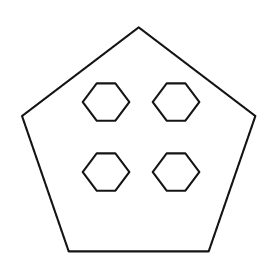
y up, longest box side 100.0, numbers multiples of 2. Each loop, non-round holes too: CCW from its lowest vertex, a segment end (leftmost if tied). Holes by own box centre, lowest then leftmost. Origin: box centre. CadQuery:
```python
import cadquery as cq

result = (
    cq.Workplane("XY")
    .moveTo(-30.0, -48.0)
    .lineTo(30.0, -48.0)
    .lineTo(50.0, 10.0)
    .lineTo(0.0, 48.0)
    .lineTo(-50.0, 10.0)
    .close()
    .moveTo(-18.0, -22.0)
    .lineTo(-10.0, -22.0)
    .lineTo(-4.0, -14.0)
    .lineTo(-10.0, -6.0)
    .lineTo(-18.0, -6.0)
    .lineTo(-24.0, -14.0)
    .close()
    .moveTo(12.0, -22.0)
    .lineTo(20.0, -22.0)
    .lineTo(26.0, -14.0)
    .lineTo(20.0, -6.0)
    .lineTo(12.0, -6.0)
    .lineTo(6.0, -14.0)
    .close()
    .moveTo(-18.0, 8.0)
    .lineTo(-10.0, 8.0)
    .lineTo(-4.0, 16.0)
    .lineTo(-10.0, 24.0)
    .lineTo(-18.0, 24.0)
    .lineTo(-24.0, 16.0)
    .close()
    .moveTo(12.0, 8.0)
    .lineTo(20.0, 8.0)
    .lineTo(26.0, 16.0)
    .lineTo(20.0, 24.0)
    .lineTo(12.0, 24.0)
    .lineTo(6.0, 16.0)
    .close()
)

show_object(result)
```